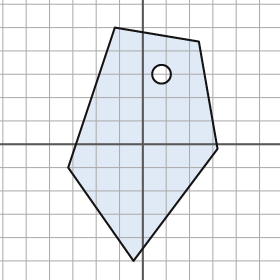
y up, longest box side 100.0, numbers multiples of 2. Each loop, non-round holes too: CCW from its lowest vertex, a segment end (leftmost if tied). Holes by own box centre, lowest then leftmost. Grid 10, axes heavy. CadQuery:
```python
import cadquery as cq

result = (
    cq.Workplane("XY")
    .moveTo(-4.0, -50.0)
    .lineTo(32.0, -2.0)
    .lineTo(24.0, 44.0)
    .lineTo(-12.0, 50.0)
    .lineTo(-32.0, -10.0)
    .close()
    .moveTo(8.0, 30.0)
    .circle(4.0)
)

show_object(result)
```